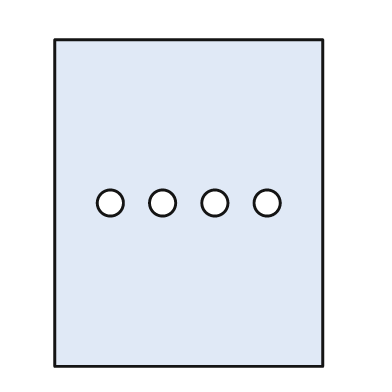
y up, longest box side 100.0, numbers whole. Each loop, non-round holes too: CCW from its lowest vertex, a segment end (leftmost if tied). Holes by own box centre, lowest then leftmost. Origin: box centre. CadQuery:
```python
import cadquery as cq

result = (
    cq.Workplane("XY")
    .moveTo(-41.0, -50.0)
    .lineTo(41.0, -50.0)
    .lineTo(41.0, 50.0)
    .lineTo(-41.0, 50.0)
    .close()
    .moveTo(-24.0, 0.0)
    .circle(4.0)
    .moveTo(-8.0, 0.0)
    .circle(4.0)
    .moveTo(8.0, 0.0)
    .circle(4.0)
    .moveTo(24.0, 0.0)
    .circle(4.0)
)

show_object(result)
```